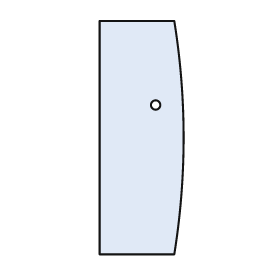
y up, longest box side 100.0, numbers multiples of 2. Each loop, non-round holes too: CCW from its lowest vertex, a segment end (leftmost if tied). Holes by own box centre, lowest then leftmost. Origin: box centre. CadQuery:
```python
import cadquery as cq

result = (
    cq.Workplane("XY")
    .moveTo(-18.0, -50.0)
    .lineTo(14.0, -50.0)
    .threePointArc((18.0, 0.0), (14.0, 50.0))
    .lineTo(-18.0, 50.0)
    .close()
    .moveTo(6.0, 14.0)
    .circle(2.0)
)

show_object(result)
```